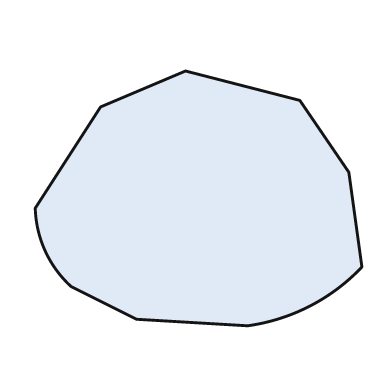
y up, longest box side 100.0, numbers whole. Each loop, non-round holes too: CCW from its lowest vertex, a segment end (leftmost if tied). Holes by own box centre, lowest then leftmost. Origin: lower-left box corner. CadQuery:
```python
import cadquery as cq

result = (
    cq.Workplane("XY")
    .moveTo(65.0, 0.0)
    .threePointArc((84.0, 6.0), (100.0, 18.0))
    .lineTo(96.0, 47.0)
    .lineTo(81.0, 69.0)
    .lineTo(46.0, 78.0)
    .lineTo(20.0, 67.0)
    .lineTo(0.0, 36.0)
    .threePointArc((3.0, 23.0), (11.0, 12.0))
    .lineTo(31.0, 2.0)
    .close()
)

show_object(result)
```